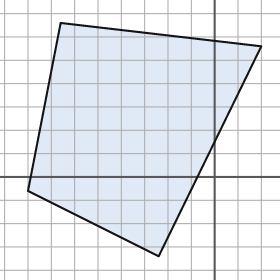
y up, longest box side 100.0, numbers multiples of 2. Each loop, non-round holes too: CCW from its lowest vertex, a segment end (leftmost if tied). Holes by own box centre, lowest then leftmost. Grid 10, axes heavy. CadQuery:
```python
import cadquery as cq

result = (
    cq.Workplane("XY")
    .moveTo(-24.0, -34.0)
    .lineTo(20.0, 56.0)
    .lineTo(-66.0, 66.0)
    .lineTo(-80.0, -6.0)
    .close()
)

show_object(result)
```